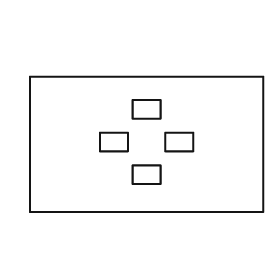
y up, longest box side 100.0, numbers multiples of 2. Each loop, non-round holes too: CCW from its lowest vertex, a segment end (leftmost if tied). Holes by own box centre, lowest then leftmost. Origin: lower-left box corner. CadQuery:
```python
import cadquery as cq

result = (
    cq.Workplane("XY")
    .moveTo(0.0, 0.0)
    .lineTo(100.0, 0.0)
    .lineTo(100.0, 58.0)
    .lineTo(0.0, 58.0)
    .close()
    .moveTo(44.0, 12.0)
    .lineTo(56.0, 12.0)
    .lineTo(56.0, 20.0)
    .lineTo(44.0, 20.0)
    .close()
    .moveTo(30.0, 26.0)
    .lineTo(42.0, 26.0)
    .lineTo(42.0, 34.0)
    .lineTo(30.0, 34.0)
    .close()
    .moveTo(58.0, 26.0)
    .lineTo(70.0, 26.0)
    .lineTo(70.0, 34.0)
    .lineTo(58.0, 34.0)
    .close()
    .moveTo(44.0, 40.0)
    .lineTo(56.0, 40.0)
    .lineTo(56.0, 48.0)
    .lineTo(44.0, 48.0)
    .close()
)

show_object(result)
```